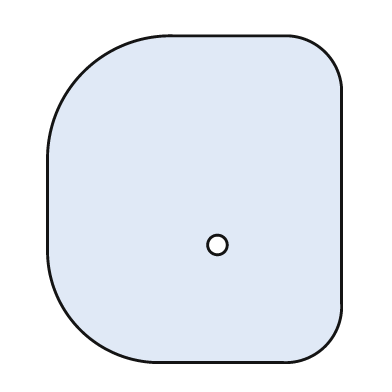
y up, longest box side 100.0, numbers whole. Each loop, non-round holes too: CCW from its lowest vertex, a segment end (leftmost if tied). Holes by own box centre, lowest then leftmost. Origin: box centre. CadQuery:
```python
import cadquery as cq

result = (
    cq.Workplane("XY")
    .moveTo(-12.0, -50.0)
    .lineTo(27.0, -50.0)
    .threePointArc((40.0, -45.0), (45.0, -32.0))
    .lineTo(45.0, 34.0)
    .threePointArc((40.0, 45.0), (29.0, 50.0))
    .lineTo(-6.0, 50.0)
    .threePointArc((-34.0, 39.0), (-45.0, 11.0))
    .lineTo(-45.0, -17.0)
    .threePointArc((-35.0, -40.0), (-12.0, -50.0))
    .close()
    .moveTo(7.0, -14.0)
    .circle(3.0)
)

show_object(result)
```